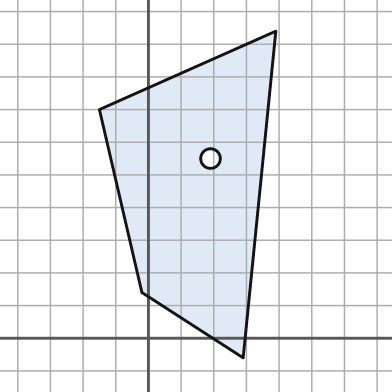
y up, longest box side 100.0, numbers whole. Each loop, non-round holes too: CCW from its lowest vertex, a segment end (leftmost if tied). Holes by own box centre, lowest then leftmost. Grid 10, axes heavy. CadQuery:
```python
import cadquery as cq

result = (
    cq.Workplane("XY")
    .moveTo(29.0, -6.0)
    .lineTo(39.0, 94.0)
    .lineTo(-15.0, 70.0)
    .lineTo(-2.0, 14.0)
    .close()
    .moveTo(19.0, 55.0)
    .circle(3.0)
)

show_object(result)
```